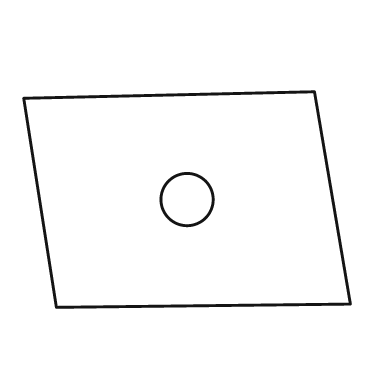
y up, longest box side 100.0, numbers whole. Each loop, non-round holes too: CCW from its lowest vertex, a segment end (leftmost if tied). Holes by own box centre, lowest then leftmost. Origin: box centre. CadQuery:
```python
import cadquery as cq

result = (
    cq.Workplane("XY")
    .moveTo(-40.0, -33.0)
    .lineTo(50.0, -32.0)
    .lineTo(39.0, 33.0)
    .lineTo(-50.0, 31.0)
    .close()
    .moveTo(0.0, 0.0)
    .circle(8.0)
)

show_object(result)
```